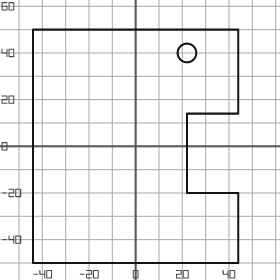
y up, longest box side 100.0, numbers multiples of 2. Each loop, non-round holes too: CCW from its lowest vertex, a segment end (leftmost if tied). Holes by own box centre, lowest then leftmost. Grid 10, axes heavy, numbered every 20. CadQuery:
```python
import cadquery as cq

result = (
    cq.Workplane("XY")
    .moveTo(-44.0, -50.0)
    .lineTo(44.0, -50.0)
    .lineTo(44.0, -20.0)
    .lineTo(22.0, -20.0)
    .lineTo(22.0, 14.0)
    .lineTo(44.0, 14.0)
    .lineTo(44.0, 50.0)
    .lineTo(-44.0, 50.0)
    .close()
    .moveTo(22.0, 40.0)
    .circle(4.0)
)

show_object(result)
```